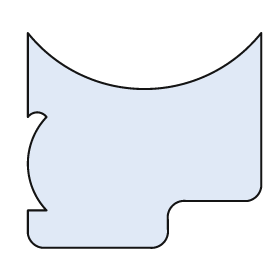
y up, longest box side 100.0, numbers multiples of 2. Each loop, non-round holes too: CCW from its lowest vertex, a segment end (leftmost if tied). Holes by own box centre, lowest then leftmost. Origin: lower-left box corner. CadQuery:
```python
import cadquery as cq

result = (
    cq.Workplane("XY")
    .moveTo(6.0, 0.0)
    .lineTo(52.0, 0.0)
    .threePointArc((58.0, 2.0), (60.0, 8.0))
    .lineTo(60.0, 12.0)
    .threePointArc((62.0, 18.0), (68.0, 20.0))
    .lineTo(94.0, 20.0)
    .threePointArc((98.0, 22.0), (100.0, 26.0))
    .lineTo(100.0, 92.0)
    .threePointArc((50.0, 68.0), (0.0, 92.0))
    .lineTo(0.0, 56.0)
    .threePointArc((4.0, 58.0), (8.0, 56.0))
    .threePointArc((0.0, 36.0), (8.0, 16.0))
    .lineTo(0.0, 16.0)
    .lineTo(0.0, 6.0)
    .threePointArc((2.0, 2.0), (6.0, 0.0))
    .close()
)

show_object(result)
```